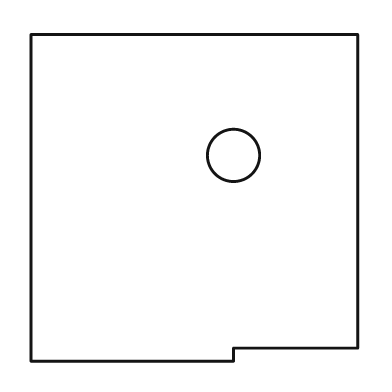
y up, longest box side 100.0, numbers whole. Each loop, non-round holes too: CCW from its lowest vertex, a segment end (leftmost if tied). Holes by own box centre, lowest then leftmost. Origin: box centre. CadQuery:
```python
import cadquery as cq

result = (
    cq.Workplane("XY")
    .moveTo(-50.0, -50.0)
    .lineTo(12.0, -50.0)
    .lineTo(12.0, -46.0)
    .lineTo(50.0, -46.0)
    .lineTo(50.0, 50.0)
    .lineTo(-50.0, 50.0)
    .close()
    .moveTo(12.0, 13.0)
    .circle(8.0)
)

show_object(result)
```